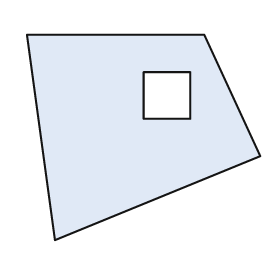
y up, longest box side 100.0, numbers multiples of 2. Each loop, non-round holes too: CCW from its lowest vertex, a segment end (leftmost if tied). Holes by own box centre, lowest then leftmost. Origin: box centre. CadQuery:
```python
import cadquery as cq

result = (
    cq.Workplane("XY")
    .moveTo(-38.0, -44.0)
    .lineTo(50.0, -8.0)
    .lineTo(26.0, 44.0)
    .lineTo(-50.0, 44.0)
    .close()
    .moveTo(0.0, 8.0)
    .lineTo(20.0, 8.0)
    .lineTo(20.0, 28.0)
    .lineTo(0.0, 28.0)
    .close()
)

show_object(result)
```